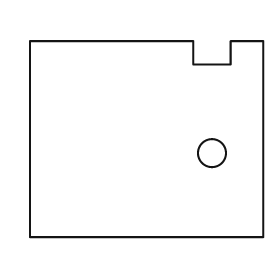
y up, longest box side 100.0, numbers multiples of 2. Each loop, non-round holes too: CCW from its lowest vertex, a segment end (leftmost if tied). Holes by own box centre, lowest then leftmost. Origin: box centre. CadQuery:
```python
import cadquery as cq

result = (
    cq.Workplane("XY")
    .moveTo(-50.0, -42.0)
    .lineTo(50.0, -42.0)
    .lineTo(50.0, 42.0)
    .lineTo(36.0, 42.0)
    .lineTo(36.0, 32.0)
    .lineTo(20.0, 32.0)
    .lineTo(20.0, 42.0)
    .lineTo(-50.0, 42.0)
    .close()
    .moveTo(28.0, -6.0)
    .circle(6.0)
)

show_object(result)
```